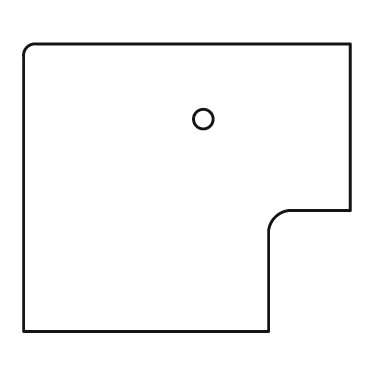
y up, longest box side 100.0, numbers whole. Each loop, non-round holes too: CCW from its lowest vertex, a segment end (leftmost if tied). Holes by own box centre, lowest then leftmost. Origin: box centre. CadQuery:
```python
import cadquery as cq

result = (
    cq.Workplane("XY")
    .moveTo(-50.0, -44.0)
    .lineTo(25.0, -44.0)
    .lineTo(25.0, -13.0)
    .threePointArc((27.0, -9.0), (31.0, -7.0))
    .lineTo(50.0, -7.0)
    .lineTo(50.0, 44.0)
    .lineTo(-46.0, 44.0)
    .threePointArc((-49.0, 43.0), (-50.0, 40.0))
    .close()
    .moveTo(5.0, 21.0)
    .circle(3.0)
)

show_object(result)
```